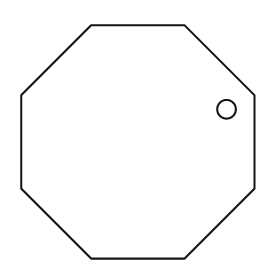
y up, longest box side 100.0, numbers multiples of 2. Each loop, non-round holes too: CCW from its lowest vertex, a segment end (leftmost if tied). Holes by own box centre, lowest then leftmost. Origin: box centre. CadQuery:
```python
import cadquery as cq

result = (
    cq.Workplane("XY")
    .moveTo(-20.0, -50.0)
    .lineTo(20.0, -50.0)
    .lineTo(50.0, -20.0)
    .lineTo(50.0, 20.0)
    .lineTo(20.0, 50.0)
    .lineTo(-20.0, 50.0)
    .lineTo(-50.0, 20.0)
    .lineTo(-50.0, -20.0)
    .close()
    .moveTo(38.0, 14.0)
    .circle(4.0)
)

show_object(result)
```